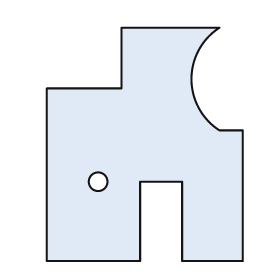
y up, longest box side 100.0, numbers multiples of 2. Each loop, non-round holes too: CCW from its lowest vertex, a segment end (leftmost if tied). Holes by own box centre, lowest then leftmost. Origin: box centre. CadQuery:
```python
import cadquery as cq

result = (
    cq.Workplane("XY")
    .moveTo(-42.0, -50.0)
    .lineTo(-2.0, -50.0)
    .lineTo(-2.0, -16.0)
    .lineTo(16.0, -16.0)
    .lineTo(16.0, -50.0)
    .lineTo(42.0, -50.0)
    .lineTo(42.0, 6.0)
    .lineTo(32.0, 6.0)
    .threePointArc((20.0, 28.0), (32.0, 50.0))
    .lineTo(-10.0, 50.0)
    .lineTo(-10.0, 24.0)
    .lineTo(-42.0, 24.0)
    .close()
    .moveTo(-20.0, -16.0)
    .circle(4.0)
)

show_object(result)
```